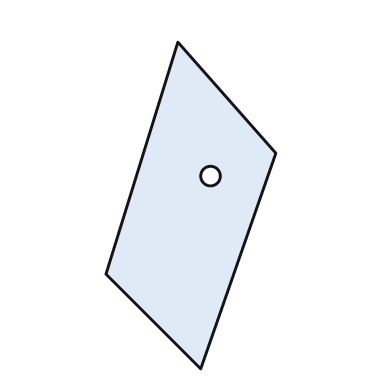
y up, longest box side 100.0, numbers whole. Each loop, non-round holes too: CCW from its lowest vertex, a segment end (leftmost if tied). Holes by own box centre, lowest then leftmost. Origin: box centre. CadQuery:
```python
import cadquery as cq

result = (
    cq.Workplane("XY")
    .moveTo(3.0, -50.0)
    .lineTo(26.0, 16.0)
    .lineTo(-4.0, 50.0)
    .lineTo(-26.0, -21.0)
    .close()
    .moveTo(6.0, 9.0)
    .circle(3.0)
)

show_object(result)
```